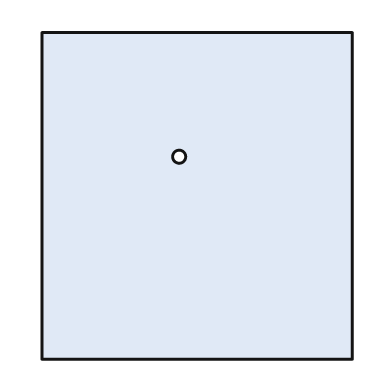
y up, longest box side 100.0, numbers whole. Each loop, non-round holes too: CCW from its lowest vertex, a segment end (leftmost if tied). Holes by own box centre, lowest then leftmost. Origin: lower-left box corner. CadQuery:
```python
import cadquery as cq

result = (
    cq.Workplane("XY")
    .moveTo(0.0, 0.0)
    .lineTo(95.0, 0.0)
    .lineTo(95.0, 100.0)
    .lineTo(0.0, 100.0)
    .close()
    .moveTo(42.0, 62.0)
    .circle(2.0)
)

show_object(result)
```